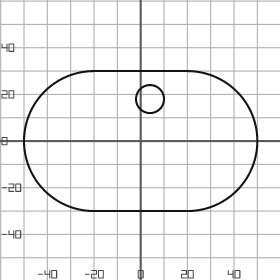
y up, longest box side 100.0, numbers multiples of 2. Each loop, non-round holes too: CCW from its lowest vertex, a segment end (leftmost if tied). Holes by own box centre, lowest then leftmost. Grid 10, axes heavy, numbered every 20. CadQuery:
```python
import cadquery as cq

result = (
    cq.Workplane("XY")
    .moveTo(-20.0, -30.0)
    .lineTo(20.0, -30.0)
    .threePointArc((50.0, 0.0), (20.0, 30.0))
    .lineTo(-20.0, 30.0)
    .threePointArc((-50.0, 0.0), (-20.0, -30.0))
    .close()
    .moveTo(4.0, 18.0)
    .circle(6.0)
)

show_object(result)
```